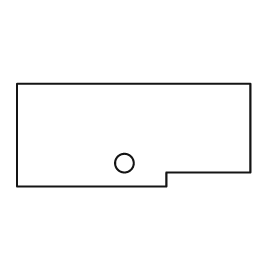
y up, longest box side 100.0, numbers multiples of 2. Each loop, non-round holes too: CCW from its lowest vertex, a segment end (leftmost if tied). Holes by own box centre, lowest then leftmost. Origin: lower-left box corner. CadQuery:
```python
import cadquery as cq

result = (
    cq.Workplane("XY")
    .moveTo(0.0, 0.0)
    .lineTo(64.0, 0.0)
    .lineTo(64.0, 6.0)
    .lineTo(100.0, 6.0)
    .lineTo(100.0, 44.0)
    .lineTo(0.0, 44.0)
    .close()
    .moveTo(46.0, 10.0)
    .circle(4.0)
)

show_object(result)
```